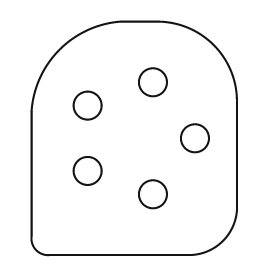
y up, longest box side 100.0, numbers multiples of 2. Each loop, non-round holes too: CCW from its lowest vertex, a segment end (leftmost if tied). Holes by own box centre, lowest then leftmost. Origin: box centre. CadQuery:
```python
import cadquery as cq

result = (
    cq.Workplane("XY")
    .moveTo(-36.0, -50.0)
    .lineTo(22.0, -50.0)
    .threePointArc((38.0, -44.0), (44.0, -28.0))
    .lineTo(44.0, 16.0)
    .threePointArc((34.0, 40.0), (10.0, 50.0))
    .lineTo(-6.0, 50.0)
    .threePointArc((-32.0, 38.0), (-44.0, 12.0))
    .lineTo(-44.0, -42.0)
    .threePointArc((-42.0, -48.0), (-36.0, -50.0))
    .close()
    .moveTo(8.0, -24.0)
    .circle(6.0)
    .moveTo(-20.0, -14.0)
    .circle(6.0)
    .moveTo(26.0, 0.0)
    .circle(6.0)
    .moveTo(-20.0, 14.0)
    .circle(6.0)
    .moveTo(8.0, 24.0)
    .circle(6.0)
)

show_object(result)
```